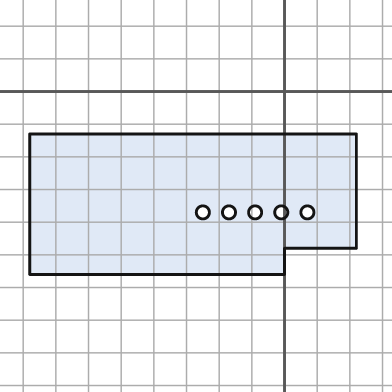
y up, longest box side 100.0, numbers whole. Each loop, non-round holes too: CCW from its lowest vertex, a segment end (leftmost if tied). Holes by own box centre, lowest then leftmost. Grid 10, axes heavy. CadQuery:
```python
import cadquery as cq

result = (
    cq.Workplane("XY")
    .moveTo(-78.0, -56.0)
    .lineTo(0.0, -56.0)
    .lineTo(0.0, -48.0)
    .lineTo(22.0, -48.0)
    .lineTo(22.0, -13.0)
    .lineTo(-78.0, -13.0)
    .close()
    .moveTo(-25.0, -37.0)
    .circle(2.0)
    .moveTo(-17.0, -37.0)
    .circle(2.0)
    .moveTo(-9.0, -37.0)
    .circle(2.0)
    .moveTo(-1.0, -37.0)
    .circle(2.0)
    .moveTo(7.0, -37.0)
    .circle(2.0)
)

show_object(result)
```